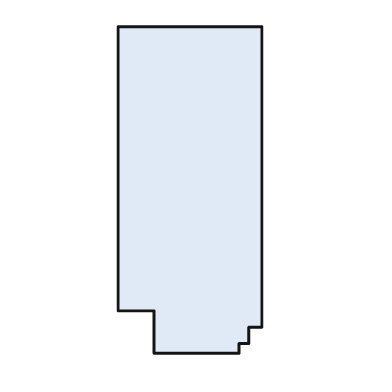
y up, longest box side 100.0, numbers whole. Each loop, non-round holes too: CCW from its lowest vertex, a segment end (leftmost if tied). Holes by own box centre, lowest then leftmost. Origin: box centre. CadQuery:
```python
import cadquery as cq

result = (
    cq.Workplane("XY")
    .moveTo(-11.0, -50.0)
    .lineTo(15.0, -50.0)
    .lineTo(15.0, -47.0)
    .lineTo(18.0, -47.0)
    .lineTo(18.0, -42.0)
    .lineTo(22.0, -42.0)
    .lineTo(22.0, 50.0)
    .lineTo(-22.0, 50.0)
    .lineTo(-22.0, -37.0)
    .lineTo(-11.0, -37.0)
    .close()
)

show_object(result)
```